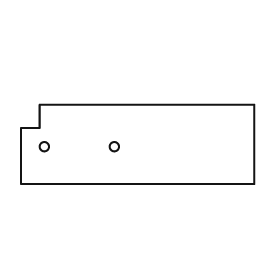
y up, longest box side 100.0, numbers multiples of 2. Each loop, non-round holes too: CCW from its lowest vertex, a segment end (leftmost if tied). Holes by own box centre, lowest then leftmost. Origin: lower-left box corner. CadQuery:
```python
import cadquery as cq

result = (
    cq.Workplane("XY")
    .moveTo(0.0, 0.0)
    .lineTo(100.0, 0.0)
    .lineTo(100.0, 34.0)
    .lineTo(8.0, 34.0)
    .lineTo(8.0, 24.0)
    .lineTo(0.0, 24.0)
    .close()
    .moveTo(10.0, 16.0)
    .circle(2.0)
    .moveTo(40.0, 16.0)
    .circle(2.0)
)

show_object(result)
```